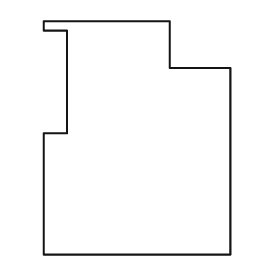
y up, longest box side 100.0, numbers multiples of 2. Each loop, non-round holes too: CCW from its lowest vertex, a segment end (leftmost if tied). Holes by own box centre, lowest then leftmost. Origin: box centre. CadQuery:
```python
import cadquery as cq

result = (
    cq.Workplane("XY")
    .moveTo(-40.0, -50.0)
    .lineTo(40.0, -50.0)
    .lineTo(40.0, 30.0)
    .lineTo(14.0, 30.0)
    .lineTo(14.0, 50.0)
    .lineTo(-40.0, 50.0)
    .lineTo(-40.0, 46.0)
    .lineTo(-30.0, 46.0)
    .lineTo(-30.0, 2.0)
    .lineTo(-40.0, 2.0)
    .close()
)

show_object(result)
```